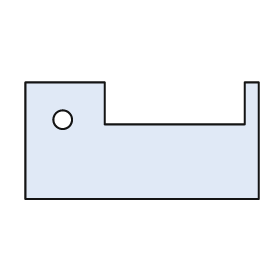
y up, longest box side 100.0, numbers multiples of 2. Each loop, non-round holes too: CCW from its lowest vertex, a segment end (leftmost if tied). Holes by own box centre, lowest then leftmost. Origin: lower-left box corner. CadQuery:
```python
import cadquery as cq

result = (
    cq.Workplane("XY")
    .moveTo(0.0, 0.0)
    .lineTo(100.0, 0.0)
    .lineTo(100.0, 50.0)
    .lineTo(94.0, 50.0)
    .lineTo(94.0, 32.0)
    .lineTo(34.0, 32.0)
    .lineTo(34.0, 50.0)
    .lineTo(0.0, 50.0)
    .close()
    .moveTo(16.0, 34.0)
    .circle(4.0)
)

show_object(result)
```